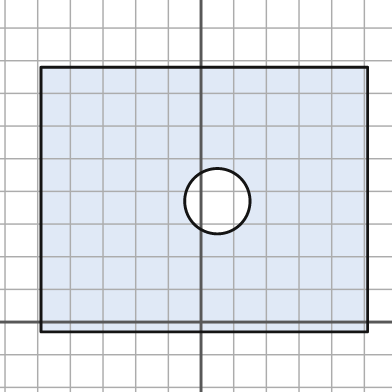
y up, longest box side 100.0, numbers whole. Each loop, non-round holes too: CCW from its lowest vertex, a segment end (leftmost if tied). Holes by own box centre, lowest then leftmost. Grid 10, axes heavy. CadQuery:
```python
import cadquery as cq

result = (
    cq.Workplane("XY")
    .moveTo(-49.0, -3.0)
    .lineTo(51.0, -3.0)
    .lineTo(51.0, 78.0)
    .lineTo(-49.0, 78.0)
    .close()
    .moveTo(5.0, 37.0)
    .circle(10.0)
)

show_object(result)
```